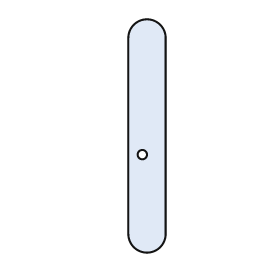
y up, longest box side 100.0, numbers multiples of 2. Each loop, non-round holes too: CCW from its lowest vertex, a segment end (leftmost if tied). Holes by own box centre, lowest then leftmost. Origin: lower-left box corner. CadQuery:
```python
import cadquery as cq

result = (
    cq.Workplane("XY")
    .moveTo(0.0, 8.0)
    .threePointArc((8.0, 0.0), (16.0, 8.0))
    .lineTo(16.0, 92.0)
    .threePointArc((8.0, 100.0), (0.0, 92.0))
    .close()
    .moveTo(6.0, 42.0)
    .circle(2.0)
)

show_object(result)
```